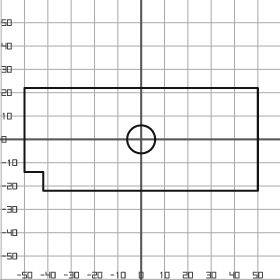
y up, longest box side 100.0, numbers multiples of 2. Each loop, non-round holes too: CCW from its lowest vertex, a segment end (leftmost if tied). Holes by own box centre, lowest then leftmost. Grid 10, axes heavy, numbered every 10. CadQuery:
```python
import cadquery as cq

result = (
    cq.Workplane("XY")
    .moveTo(-42.0, -22.0)
    .lineTo(50.0, -22.0)
    .lineTo(50.0, 22.0)
    .lineTo(-50.0, 22.0)
    .lineTo(-50.0, -14.0)
    .lineTo(-42.0, -14.0)
    .close()
    .moveTo(0.0, 0.0)
    .circle(6.0)
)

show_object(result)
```